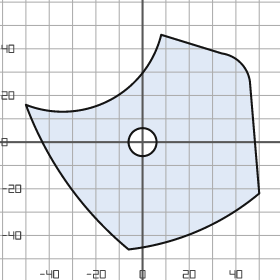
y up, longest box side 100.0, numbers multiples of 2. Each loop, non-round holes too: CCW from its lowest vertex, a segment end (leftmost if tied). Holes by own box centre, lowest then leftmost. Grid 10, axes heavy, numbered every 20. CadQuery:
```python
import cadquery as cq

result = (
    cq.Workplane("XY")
    .moveTo(-6.0, -46.0)
    .threePointArc((24.0, -38.0), (50.0, -22.0))
    .lineTo(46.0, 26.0)
    .threePointArc((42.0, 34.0), (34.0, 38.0))
    .lineTo(8.0, 46.0)
    .threePointArc((-14.0, 18.0), (-50.0, 16.0))
    .threePointArc((-32.0, -18.0), (-6.0, -46.0))
    .close()
    .moveTo(0.0, 0.0)
    .circle(6.0)
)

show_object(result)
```